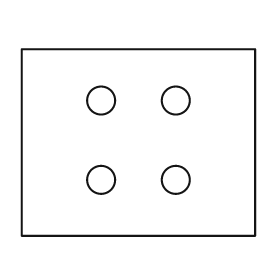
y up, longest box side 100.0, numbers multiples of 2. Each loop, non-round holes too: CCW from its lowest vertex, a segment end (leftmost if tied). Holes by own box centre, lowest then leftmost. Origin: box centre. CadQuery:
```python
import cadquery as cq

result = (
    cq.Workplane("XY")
    .moveTo(-50.0, -40.0)
    .lineTo(50.0, -40.0)
    .lineTo(50.0, 40.0)
    .lineTo(-50.0, 40.0)
    .close()
    .moveTo(-16.0, -16.0)
    .circle(6.0)
    .moveTo(16.0, -16.0)
    .circle(6.0)
    .moveTo(-16.0, 18.0)
    .circle(6.0)
    .moveTo(16.0, 18.0)
    .circle(6.0)
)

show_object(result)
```